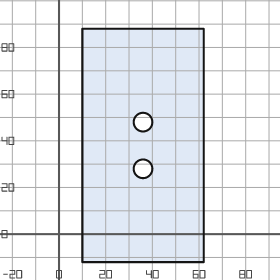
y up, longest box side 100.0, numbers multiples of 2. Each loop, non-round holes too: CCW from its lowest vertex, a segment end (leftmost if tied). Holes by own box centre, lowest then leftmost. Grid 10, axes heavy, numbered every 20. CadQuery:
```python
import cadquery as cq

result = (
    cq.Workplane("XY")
    .moveTo(10.0, -12.0)
    .lineTo(62.0, -12.0)
    .lineTo(62.0, 88.0)
    .lineTo(10.0, 88.0)
    .close()
    .moveTo(36.0, 28.0)
    .circle(4.0)
    .moveTo(36.0, 48.0)
    .circle(4.0)
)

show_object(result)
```